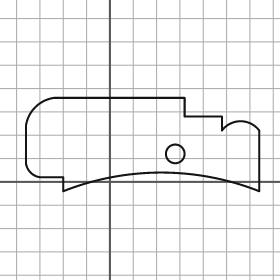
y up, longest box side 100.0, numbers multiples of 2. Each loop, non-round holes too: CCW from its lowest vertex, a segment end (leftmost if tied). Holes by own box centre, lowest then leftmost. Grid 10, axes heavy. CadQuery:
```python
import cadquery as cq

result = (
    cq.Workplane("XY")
    .moveTo(-20.0, -4.0)
    .threePointArc((22.0, 4.0), (64.0, -4.0))
    .lineTo(64.0, 22.0)
    .threePointArc((56.0, 26.0), (48.0, 22.0))
    .lineTo(48.0, 28.0)
    .lineTo(32.0, 28.0)
    .lineTo(32.0, 36.0)
    .lineTo(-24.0, 36.0)
    .threePointArc((-32.0, 32.0), (-36.0, 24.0))
    .lineTo(-36.0, 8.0)
    .threePointArc((-34.0, 4.0), (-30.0, 2.0))
    .lineTo(-20.0, 2.0)
    .close()
    .moveTo(28.0, 12.0)
    .circle(4.0)
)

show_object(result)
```